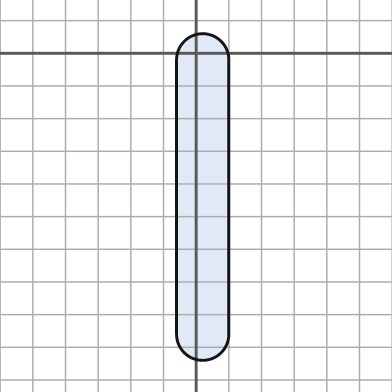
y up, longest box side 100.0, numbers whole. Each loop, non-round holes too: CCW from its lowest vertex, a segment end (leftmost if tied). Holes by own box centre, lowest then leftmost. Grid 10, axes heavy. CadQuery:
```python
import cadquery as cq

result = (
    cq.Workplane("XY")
    .moveTo(-6.0, -86.0)
    .threePointArc((2.0, -94.0), (10.0, -86.0))
    .lineTo(10.0, -2.0)
    .threePointArc((2.0, 6.0), (-6.0, -2.0))
    .close()
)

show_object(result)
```